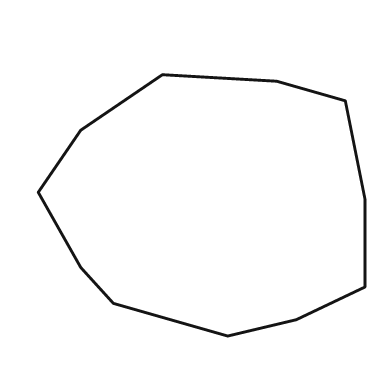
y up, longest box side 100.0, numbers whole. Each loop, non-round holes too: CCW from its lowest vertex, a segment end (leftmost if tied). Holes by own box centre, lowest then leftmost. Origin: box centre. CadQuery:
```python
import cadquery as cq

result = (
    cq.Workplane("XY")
    .moveTo(8.0, -40.0)
    .lineTo(29.0, -35.0)
    .lineTo(50.0, -25.0)
    .lineTo(50.0, 2.0)
    .lineTo(44.0, 32.0)
    .lineTo(23.0, 38.0)
    .lineTo(-12.0, 40.0)
    .lineTo(-37.0, 23.0)
    .lineTo(-50.0, 4.0)
    .lineTo(-37.0, -19.0)
    .lineTo(-27.0, -30.0)
    .close()
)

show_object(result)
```